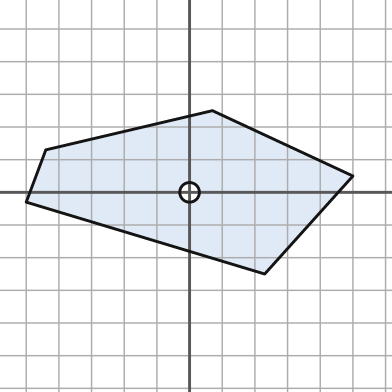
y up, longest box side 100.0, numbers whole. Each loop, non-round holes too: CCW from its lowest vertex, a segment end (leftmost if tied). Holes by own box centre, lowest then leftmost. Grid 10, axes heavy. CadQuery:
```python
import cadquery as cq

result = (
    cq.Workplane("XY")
    .moveTo(23.0, -25.0)
    .lineTo(50.0, 5.0)
    .lineTo(7.0, 25.0)
    .lineTo(-44.0, 13.0)
    .lineTo(-50.0, -3.0)
    .close()
    .moveTo(0.0, 0.0)
    .circle(3.0)
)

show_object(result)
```